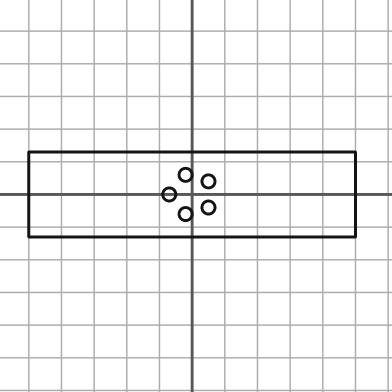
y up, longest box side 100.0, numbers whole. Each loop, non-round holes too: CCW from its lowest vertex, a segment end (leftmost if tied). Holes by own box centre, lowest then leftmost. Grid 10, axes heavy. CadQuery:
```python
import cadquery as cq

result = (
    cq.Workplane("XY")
    .moveTo(-50.0, -13.0)
    .lineTo(50.0, -13.0)
    .lineTo(50.0, 13.0)
    .lineTo(-50.0, 13.0)
    .close()
    .moveTo(-2.0, -6.0)
    .circle(2.0)
    .moveTo(5.0, -4.0)
    .circle(2.0)
    .moveTo(-7.0, 0.0)
    .circle(2.0)
    .moveTo(5.0, 4.0)
    .circle(2.0)
    .moveTo(-2.0, 6.0)
    .circle(2.0)
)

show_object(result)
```